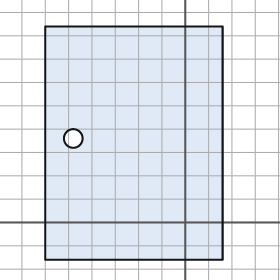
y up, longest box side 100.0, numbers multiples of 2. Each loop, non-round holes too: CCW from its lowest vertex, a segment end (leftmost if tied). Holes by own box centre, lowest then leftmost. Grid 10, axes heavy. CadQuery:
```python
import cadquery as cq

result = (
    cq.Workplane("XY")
    .moveTo(-60.0, -16.0)
    .lineTo(16.0, -16.0)
    .lineTo(16.0, 84.0)
    .lineTo(-60.0, 84.0)
    .close()
    .moveTo(-48.0, 36.0)
    .circle(4.0)
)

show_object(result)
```